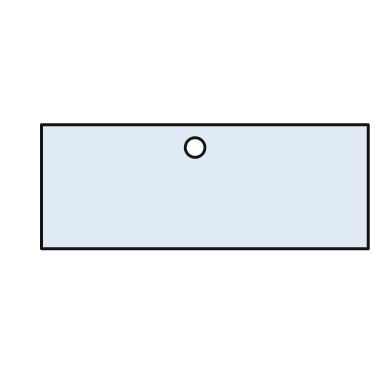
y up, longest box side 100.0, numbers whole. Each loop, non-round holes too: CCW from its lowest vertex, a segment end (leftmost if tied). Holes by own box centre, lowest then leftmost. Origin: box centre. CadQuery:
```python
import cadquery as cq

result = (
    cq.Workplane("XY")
    .moveTo(-50.0, -19.0)
    .lineTo(50.0, -19.0)
    .lineTo(50.0, 19.0)
    .lineTo(-50.0, 19.0)
    .close()
    .moveTo(-3.0, 12.0)
    .circle(3.0)
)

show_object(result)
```